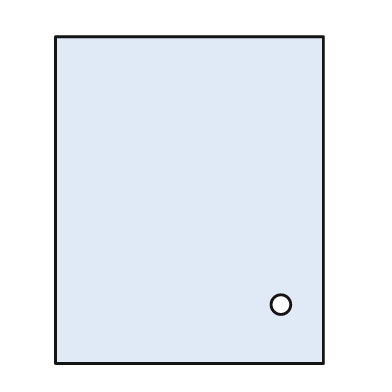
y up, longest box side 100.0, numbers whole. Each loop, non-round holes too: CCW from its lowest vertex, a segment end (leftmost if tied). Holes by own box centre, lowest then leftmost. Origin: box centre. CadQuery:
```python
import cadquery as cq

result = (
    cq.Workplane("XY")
    .moveTo(-41.0, -50.0)
    .lineTo(41.0, -50.0)
    .lineTo(41.0, 50.0)
    .lineTo(-41.0, 50.0)
    .close()
    .moveTo(28.0, -32.0)
    .circle(3.0)
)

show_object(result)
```